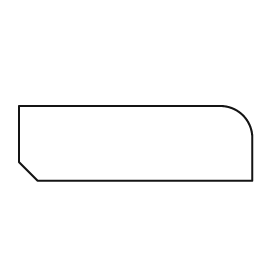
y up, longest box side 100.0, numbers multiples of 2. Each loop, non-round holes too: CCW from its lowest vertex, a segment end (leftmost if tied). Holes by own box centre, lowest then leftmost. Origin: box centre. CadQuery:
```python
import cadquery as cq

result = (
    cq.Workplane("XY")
    .moveTo(-42.0, -16.0)
    .lineTo(50.0, -16.0)
    .lineTo(50.0, 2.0)
    .threePointArc((46.0, 12.0), (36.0, 16.0))
    .lineTo(-50.0, 16.0)
    .lineTo(-50.0, -8.0)
    .close()
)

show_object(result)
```